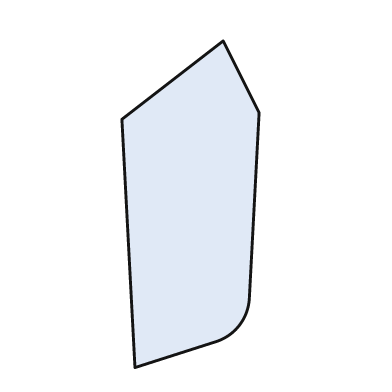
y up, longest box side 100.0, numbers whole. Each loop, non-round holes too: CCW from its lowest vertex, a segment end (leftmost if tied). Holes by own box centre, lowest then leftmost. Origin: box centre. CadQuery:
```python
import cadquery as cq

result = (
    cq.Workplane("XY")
    .moveTo(-17.0, -50.0)
    .lineTo(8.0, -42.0)
    .threePointArc((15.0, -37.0), (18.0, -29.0))
    .lineTo(21.0, 28.0)
    .lineTo(10.0, 50.0)
    .lineTo(-21.0, 26.0)
    .close()
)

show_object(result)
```